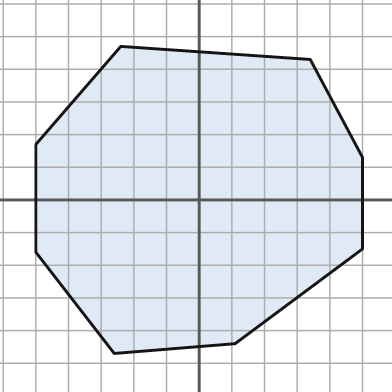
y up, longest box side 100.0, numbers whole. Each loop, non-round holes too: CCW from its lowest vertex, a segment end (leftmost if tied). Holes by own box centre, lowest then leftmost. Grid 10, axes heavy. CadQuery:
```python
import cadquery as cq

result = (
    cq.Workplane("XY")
    .moveTo(-26.0, -47.0)
    .lineTo(11.0, -44.0)
    .lineTo(50.0, -15.0)
    .lineTo(50.0, 13.0)
    .lineTo(34.0, 43.0)
    .lineTo(-24.0, 47.0)
    .lineTo(-50.0, 17.0)
    .lineTo(-50.0, -16.0)
    .close()
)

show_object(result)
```